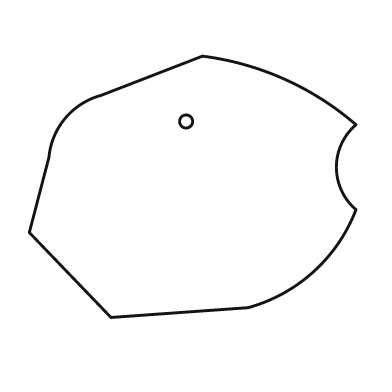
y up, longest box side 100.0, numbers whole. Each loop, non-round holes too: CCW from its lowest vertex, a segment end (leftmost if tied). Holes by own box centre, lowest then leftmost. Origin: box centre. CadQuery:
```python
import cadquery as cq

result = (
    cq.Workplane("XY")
    .moveTo(-25.0, -40.0)
    .lineTo(17.0, -37.0)
    .threePointArc((37.0, -26.0), (50.0, -7.0))
    .threePointArc((44.0, 6.0), (50.0, 19.0))
    .threePointArc((28.0, 33.0), (3.0, 40.0))
    .lineTo(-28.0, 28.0)
    .threePointArc((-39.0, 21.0), (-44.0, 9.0))
    .lineTo(-50.0, -14.0)
    .close()
    .moveTo(-2.0, 20.0)
    .circle(2.0)
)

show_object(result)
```